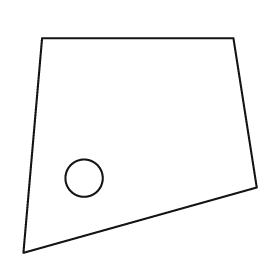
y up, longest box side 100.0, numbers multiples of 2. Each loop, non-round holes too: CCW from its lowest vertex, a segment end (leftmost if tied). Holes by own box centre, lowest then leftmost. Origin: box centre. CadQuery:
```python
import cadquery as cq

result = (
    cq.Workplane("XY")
    .moveTo(-50.0, -46.0)
    .lineTo(50.0, -18.0)
    .lineTo(40.0, 46.0)
    .lineTo(-42.0, 46.0)
    .close()
    .moveTo(-24.0, -14.0)
    .circle(8.0)
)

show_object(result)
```